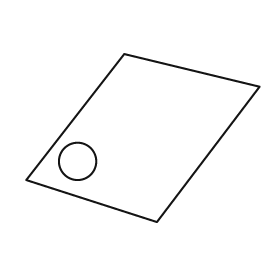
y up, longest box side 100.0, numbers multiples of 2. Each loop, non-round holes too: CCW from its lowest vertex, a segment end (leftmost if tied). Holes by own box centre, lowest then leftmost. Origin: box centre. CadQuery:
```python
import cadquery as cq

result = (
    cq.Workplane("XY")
    .moveTo(6.0, -36.0)
    .lineTo(50.0, 22.0)
    .lineTo(-8.0, 36.0)
    .lineTo(-50.0, -18.0)
    .close()
    .moveTo(-28.0, -10.0)
    .circle(8.0)
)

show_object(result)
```